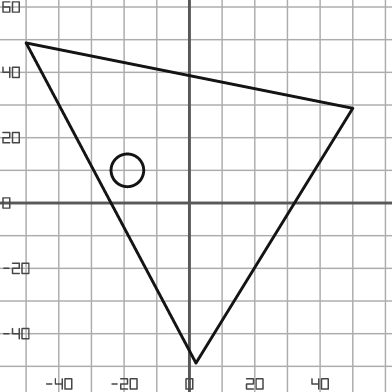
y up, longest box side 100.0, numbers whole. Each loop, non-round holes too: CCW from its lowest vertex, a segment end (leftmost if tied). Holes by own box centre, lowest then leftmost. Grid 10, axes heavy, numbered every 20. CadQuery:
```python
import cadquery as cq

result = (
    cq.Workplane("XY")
    .moveTo(2.0, -49.0)
    .lineTo(50.0, 29.0)
    .lineTo(-50.0, 49.0)
    .close()
    .moveTo(-19.0, 10.0)
    .circle(5.0)
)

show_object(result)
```